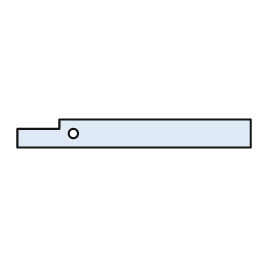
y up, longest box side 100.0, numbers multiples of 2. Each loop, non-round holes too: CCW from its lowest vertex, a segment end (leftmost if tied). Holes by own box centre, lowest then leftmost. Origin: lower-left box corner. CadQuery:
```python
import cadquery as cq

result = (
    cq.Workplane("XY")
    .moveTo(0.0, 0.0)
    .lineTo(100.0, 0.0)
    .lineTo(100.0, 12.0)
    .lineTo(18.0, 12.0)
    .lineTo(18.0, 8.0)
    .lineTo(0.0, 8.0)
    .close()
    .moveTo(24.0, 6.0)
    .circle(2.0)
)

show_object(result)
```